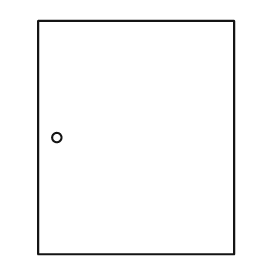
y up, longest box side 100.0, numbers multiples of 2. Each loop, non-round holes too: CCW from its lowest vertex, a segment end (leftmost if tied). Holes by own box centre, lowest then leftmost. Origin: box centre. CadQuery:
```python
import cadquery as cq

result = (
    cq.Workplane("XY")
    .moveTo(-42.0, -50.0)
    .lineTo(42.0, -50.0)
    .lineTo(42.0, 50.0)
    .lineTo(-42.0, 50.0)
    .close()
    .moveTo(-34.0, 0.0)
    .circle(2.0)
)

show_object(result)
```